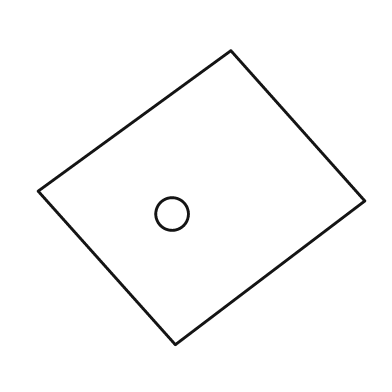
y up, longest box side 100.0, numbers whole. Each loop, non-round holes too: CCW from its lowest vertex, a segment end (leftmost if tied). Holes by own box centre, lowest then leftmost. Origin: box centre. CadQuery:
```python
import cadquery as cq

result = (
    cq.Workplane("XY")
    .moveTo(-8.0, -45.0)
    .lineTo(50.0, -1.0)
    .lineTo(9.0, 45.0)
    .lineTo(-50.0, 2.0)
    .close()
    .moveTo(-9.0, -5.0)
    .circle(5.0)
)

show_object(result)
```